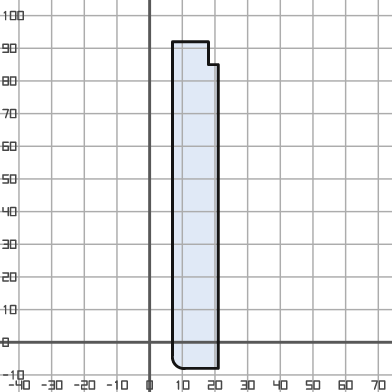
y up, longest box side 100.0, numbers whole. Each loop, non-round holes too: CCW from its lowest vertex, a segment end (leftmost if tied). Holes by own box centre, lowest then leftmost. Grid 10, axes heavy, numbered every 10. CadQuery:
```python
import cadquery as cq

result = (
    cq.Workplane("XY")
    .moveTo(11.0, -8.0)
    .lineTo(21.0, -8.0)
    .lineTo(21.0, 85.0)
    .lineTo(18.0, 85.0)
    .lineTo(18.0, 92.0)
    .lineTo(7.0, 92.0)
    .lineTo(7.0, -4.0)
    .threePointArc((8.0, -7.0), (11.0, -8.0))
    .close()
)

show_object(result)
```